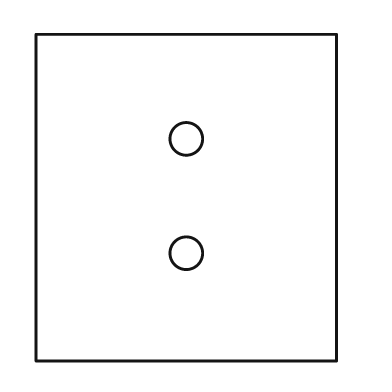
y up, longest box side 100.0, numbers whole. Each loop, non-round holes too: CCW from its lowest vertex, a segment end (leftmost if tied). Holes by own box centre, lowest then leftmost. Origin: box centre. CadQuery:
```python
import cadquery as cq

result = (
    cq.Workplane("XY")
    .moveTo(-46.0, -50.0)
    .lineTo(46.0, -50.0)
    .lineTo(46.0, 50.0)
    .lineTo(-46.0, 50.0)
    .close()
    .moveTo(0.0, -17.0)
    .circle(5.0)
    .moveTo(0.0, 18.0)
    .circle(5.0)
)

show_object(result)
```